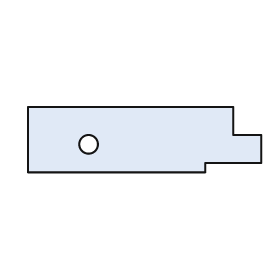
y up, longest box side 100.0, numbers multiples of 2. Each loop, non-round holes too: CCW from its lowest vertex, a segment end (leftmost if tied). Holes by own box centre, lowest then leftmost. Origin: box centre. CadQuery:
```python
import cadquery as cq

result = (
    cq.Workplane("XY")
    .moveTo(-50.0, -14.0)
    .lineTo(26.0, -14.0)
    .lineTo(26.0, -10.0)
    .lineTo(50.0, -10.0)
    .lineTo(50.0, 2.0)
    .lineTo(38.0, 2.0)
    .lineTo(38.0, 14.0)
    .lineTo(-50.0, 14.0)
    .close()
    .moveTo(-24.0, -2.0)
    .circle(4.0)
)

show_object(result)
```